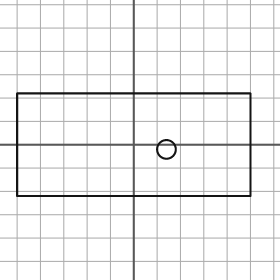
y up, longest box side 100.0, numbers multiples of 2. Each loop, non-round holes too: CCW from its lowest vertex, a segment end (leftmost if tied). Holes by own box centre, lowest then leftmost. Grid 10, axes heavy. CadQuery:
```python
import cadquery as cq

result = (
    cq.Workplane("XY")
    .moveTo(-50.0, -22.0)
    .lineTo(50.0, -22.0)
    .lineTo(50.0, 22.0)
    .lineTo(-50.0, 22.0)
    .close()
    .moveTo(14.0, -2.0)
    .circle(4.0)
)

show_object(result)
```